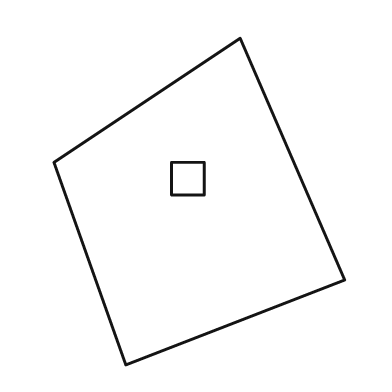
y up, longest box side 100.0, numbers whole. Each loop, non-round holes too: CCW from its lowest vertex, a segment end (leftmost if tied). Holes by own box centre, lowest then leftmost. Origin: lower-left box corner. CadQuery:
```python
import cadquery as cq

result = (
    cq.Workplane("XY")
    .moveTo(22.0, 0.0)
    .lineTo(89.0, 26.0)
    .lineTo(57.0, 100.0)
    .lineTo(0.0, 62.0)
    .close()
    .moveTo(36.0, 52.0)
    .lineTo(46.0, 52.0)
    .lineTo(46.0, 62.0)
    .lineTo(36.0, 62.0)
    .close()
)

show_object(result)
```